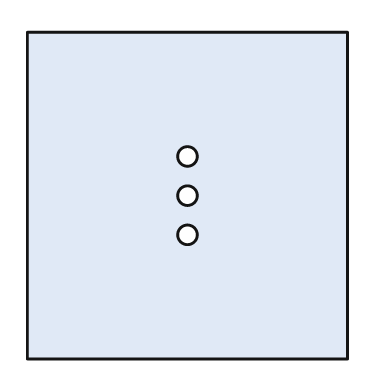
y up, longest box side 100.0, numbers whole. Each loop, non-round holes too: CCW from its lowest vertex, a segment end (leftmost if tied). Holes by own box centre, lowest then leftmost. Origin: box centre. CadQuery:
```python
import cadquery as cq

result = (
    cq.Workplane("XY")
    .moveTo(-49.0, -50.0)
    .lineTo(49.0, -50.0)
    .lineTo(49.0, 50.0)
    .lineTo(-49.0, 50.0)
    .close()
    .moveTo(0.0, -12.0)
    .circle(3.0)
    .moveTo(0.0, 0.0)
    .circle(3.0)
    .moveTo(0.0, 12.0)
    .circle(3.0)
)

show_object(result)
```